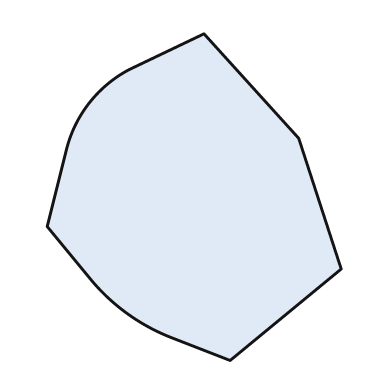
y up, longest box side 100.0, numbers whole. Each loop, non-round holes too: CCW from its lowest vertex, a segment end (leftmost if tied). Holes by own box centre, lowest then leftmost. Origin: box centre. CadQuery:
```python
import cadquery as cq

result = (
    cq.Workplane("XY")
    .moveTo(11.0, -50.0)
    .lineTo(45.0, -22.0)
    .lineTo(32.0, 18.0)
    .lineTo(3.0, 50.0)
    .lineTo(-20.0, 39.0)
    .threePointArc((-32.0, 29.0), (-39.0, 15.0))
    .lineTo(-45.0, -9.0)
    .lineTo(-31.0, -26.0)
    .threePointArc((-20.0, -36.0), (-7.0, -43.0))
    .close()
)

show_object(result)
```